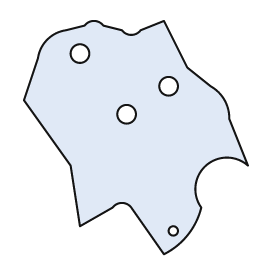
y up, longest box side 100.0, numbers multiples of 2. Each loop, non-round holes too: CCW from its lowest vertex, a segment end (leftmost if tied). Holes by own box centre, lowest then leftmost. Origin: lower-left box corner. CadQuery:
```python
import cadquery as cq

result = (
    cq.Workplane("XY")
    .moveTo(60.0, 0.0)
    .threePointArc((70.0, 8.0), (76.0, 20.0))
    .threePointArc((78.0, 38.0), (96.0, 38.0))
    .lineTo(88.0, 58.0)
    .threePointArc((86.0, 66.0), (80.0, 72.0))
    .lineTo(70.0, 80.0)
    .lineTo(60.0, 100.0)
    .lineTo(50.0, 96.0)
    .threePointArc((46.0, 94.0), (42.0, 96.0))
    .lineTo(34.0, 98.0)
    .threePointArc((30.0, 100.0), (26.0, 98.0))
    .lineTo(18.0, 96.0)
    .threePointArc((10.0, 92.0), (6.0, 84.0))
    .lineTo(0.0, 66.0)
    .lineTo(20.0, 38.0)
    .lineTo(24.0, 12.0)
    .lineTo(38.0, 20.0)
    .threePointArc((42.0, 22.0), (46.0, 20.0))
    .close()
    .moveTo(64.0, 10.0)
    .circle(2.0)
    .moveTo(44.0, 60.0)
    .circle(4.0)
    .moveTo(62.0, 72.0)
    .circle(4.0)
    .moveTo(24.0, 86.0)
    .circle(4.0)
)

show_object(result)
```